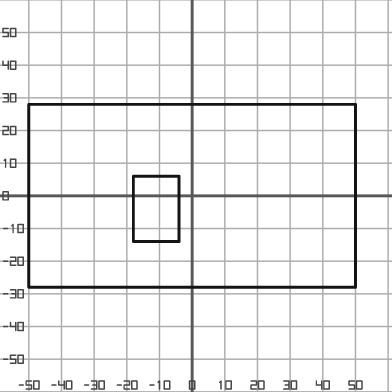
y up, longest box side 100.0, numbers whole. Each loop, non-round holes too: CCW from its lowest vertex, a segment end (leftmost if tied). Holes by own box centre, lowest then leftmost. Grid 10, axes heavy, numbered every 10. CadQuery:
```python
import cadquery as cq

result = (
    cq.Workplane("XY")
    .moveTo(-50.0, -28.0)
    .lineTo(50.0, -28.0)
    .lineTo(50.0, 28.0)
    .lineTo(-50.0, 28.0)
    .close()
    .moveTo(-18.0, -14.0)
    .lineTo(-4.0, -14.0)
    .lineTo(-4.0, 6.0)
    .lineTo(-18.0, 6.0)
    .close()
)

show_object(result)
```